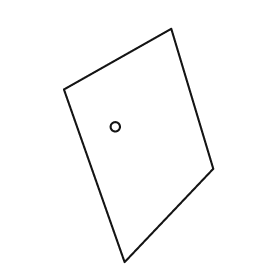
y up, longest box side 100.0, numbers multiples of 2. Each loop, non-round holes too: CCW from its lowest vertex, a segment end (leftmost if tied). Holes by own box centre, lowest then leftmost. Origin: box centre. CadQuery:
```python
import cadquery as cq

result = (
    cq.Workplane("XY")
    .moveTo(-6.0, -50.0)
    .lineTo(32.0, -10.0)
    .lineTo(14.0, 50.0)
    .lineTo(-32.0, 24.0)
    .close()
    .moveTo(-10.0, 8.0)
    .circle(2.0)
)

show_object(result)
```